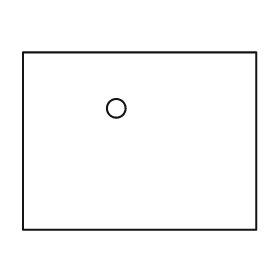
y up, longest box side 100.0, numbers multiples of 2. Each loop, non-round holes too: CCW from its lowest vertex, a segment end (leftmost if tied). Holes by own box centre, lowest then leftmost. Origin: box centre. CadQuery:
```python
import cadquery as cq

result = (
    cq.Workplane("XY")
    .moveTo(-50.0, -38.0)
    .lineTo(50.0, -38.0)
    .lineTo(50.0, 38.0)
    .lineTo(-50.0, 38.0)
    .close()
    .moveTo(-10.0, 14.0)
    .circle(4.0)
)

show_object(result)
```